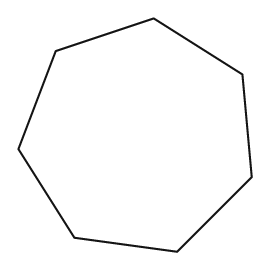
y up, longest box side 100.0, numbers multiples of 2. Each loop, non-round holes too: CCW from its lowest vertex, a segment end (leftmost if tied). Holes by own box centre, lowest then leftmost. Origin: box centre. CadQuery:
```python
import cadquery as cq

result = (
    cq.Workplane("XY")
    .moveTo(18.0, -50.0)
    .lineTo(50.0, -18.0)
    .lineTo(46.0, 26.0)
    .lineTo(8.0, 50.0)
    .lineTo(-34.0, 36.0)
    .lineTo(-50.0, -6.0)
    .lineTo(-26.0, -44.0)
    .close()
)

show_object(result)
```